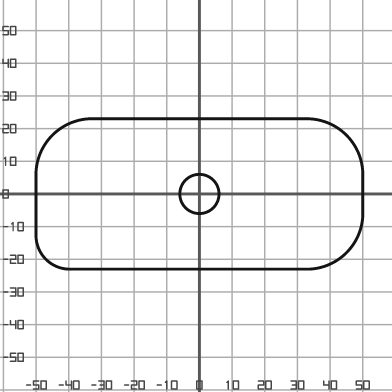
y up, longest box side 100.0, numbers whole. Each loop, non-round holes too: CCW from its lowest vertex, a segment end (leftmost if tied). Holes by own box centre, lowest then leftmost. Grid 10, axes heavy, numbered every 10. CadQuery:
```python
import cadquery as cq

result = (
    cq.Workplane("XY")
    .moveTo(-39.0, -23.0)
    .lineTo(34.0, -23.0)
    .threePointArc((45.0, -18.0), (50.0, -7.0))
    .lineTo(50.0, 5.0)
    .threePointArc((45.0, 18.0), (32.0, 23.0))
    .lineTo(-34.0, 23.0)
    .threePointArc((-45.0, 18.0), (-50.0, 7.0))
    .lineTo(-50.0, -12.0)
    .threePointArc((-47.0, -20.0), (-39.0, -23.0))
    .close()
    .moveTo(0.0, 0.0)
    .circle(6.0)
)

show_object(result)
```